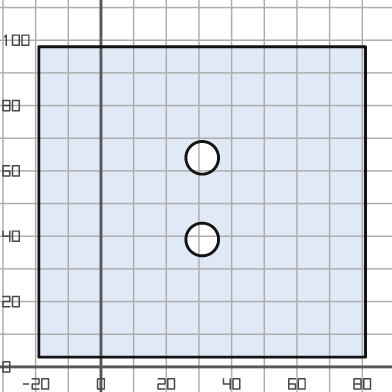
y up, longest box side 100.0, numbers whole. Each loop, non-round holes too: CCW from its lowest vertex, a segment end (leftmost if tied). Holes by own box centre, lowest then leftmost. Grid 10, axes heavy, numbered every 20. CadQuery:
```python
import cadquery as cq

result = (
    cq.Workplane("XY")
    .moveTo(-19.0, 3.0)
    .lineTo(81.0, 3.0)
    .lineTo(81.0, 98.0)
    .lineTo(-19.0, 98.0)
    .close()
    .moveTo(31.0, 39.0)
    .circle(5.0)
    .moveTo(31.0, 64.0)
    .circle(5.0)
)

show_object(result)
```